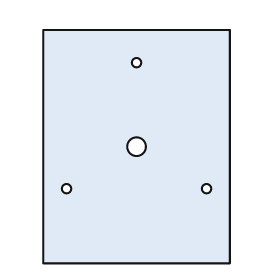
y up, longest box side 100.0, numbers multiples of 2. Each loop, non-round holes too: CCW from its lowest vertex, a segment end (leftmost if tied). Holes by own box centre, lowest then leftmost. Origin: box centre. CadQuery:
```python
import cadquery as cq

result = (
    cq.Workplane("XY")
    .moveTo(-40.0, -50.0)
    .lineTo(40.0, -50.0)
    .lineTo(40.0, 50.0)
    .lineTo(-40.0, 50.0)
    .close()
    .moveTo(-30.0, -18.0)
    .circle(2.0)
    .moveTo(30.0, -18.0)
    .circle(2.0)
    .moveTo(0.0, 0.0)
    .circle(4.0)
    .moveTo(0.0, 36.0)
    .circle(2.0)
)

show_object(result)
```